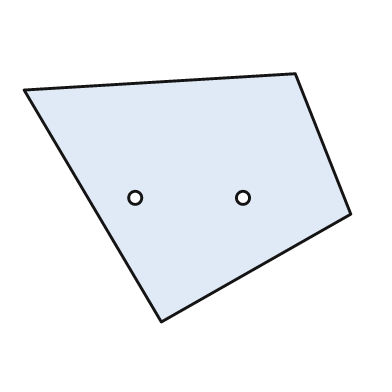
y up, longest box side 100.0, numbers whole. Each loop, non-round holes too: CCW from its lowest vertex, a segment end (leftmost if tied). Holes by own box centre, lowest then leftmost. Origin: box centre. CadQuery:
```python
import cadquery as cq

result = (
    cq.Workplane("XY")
    .moveTo(-8.0, -38.0)
    .lineTo(50.0, -5.0)
    .lineTo(33.0, 38.0)
    .lineTo(-50.0, 33.0)
    .close()
    .moveTo(-16.0, 0.0)
    .circle(2.0)
    .moveTo(17.0, 0.0)
    .circle(2.0)
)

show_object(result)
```